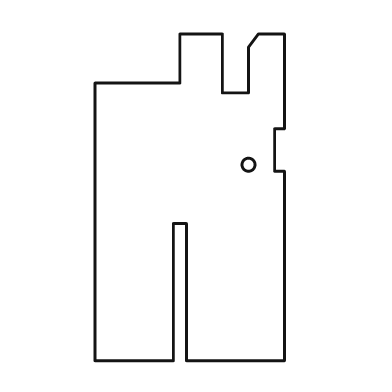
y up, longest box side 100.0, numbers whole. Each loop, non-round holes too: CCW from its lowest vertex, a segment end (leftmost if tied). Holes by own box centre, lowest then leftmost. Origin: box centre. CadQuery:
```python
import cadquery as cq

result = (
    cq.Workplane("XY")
    .moveTo(-29.0, -50.0)
    .lineTo(-5.0, -50.0)
    .lineTo(-5.0, -8.0)
    .lineTo(-1.0, -8.0)
    .lineTo(-1.0, -50.0)
    .lineTo(29.0, -50.0)
    .lineTo(29.0, 8.0)
    .lineTo(26.0, 8.0)
    .lineTo(26.0, 21.0)
    .lineTo(29.0, 21.0)
    .lineTo(29.0, 50.0)
    .lineTo(21.0, 50.0)
    .lineTo(18.0, 46.0)
    .lineTo(18.0, 32.0)
    .lineTo(10.0, 32.0)
    .lineTo(10.0, 50.0)
    .lineTo(-3.0, 50.0)
    .lineTo(-3.0, 35.0)
    .lineTo(-29.0, 35.0)
    .close()
    .moveTo(18.0, 10.0)
    .circle(2.0)
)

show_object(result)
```